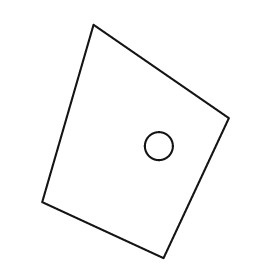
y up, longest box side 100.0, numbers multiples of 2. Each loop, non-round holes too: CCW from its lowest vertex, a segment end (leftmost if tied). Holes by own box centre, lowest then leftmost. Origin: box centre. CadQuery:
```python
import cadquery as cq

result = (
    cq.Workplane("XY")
    .moveTo(12.0, -50.0)
    .lineTo(40.0, 10.0)
    .lineTo(-18.0, 50.0)
    .lineTo(-40.0, -26.0)
    .close()
    .moveTo(10.0, -2.0)
    .circle(6.0)
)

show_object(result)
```